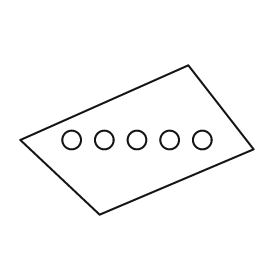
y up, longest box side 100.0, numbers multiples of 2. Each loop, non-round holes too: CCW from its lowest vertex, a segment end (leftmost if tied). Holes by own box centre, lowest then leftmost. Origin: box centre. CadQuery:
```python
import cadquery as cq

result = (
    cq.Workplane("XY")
    .moveTo(-16.0, -32.0)
    .lineTo(50.0, -4.0)
    .lineTo(22.0, 32.0)
    .lineTo(-50.0, 0.0)
    .close()
    .moveTo(-28.0, 0.0)
    .circle(4.0)
    .moveTo(-14.0, 0.0)
    .circle(4.0)
    .moveTo(0.0, 0.0)
    .circle(4.0)
    .moveTo(14.0, 0.0)
    .circle(4.0)
    .moveTo(28.0, 0.0)
    .circle(4.0)
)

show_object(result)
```